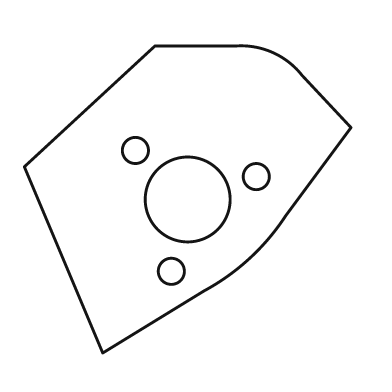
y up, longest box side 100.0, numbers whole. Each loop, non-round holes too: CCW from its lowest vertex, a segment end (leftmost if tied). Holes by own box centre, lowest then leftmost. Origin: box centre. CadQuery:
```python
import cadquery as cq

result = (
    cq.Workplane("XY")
    .moveTo(-26.0, -47.0)
    .lineTo(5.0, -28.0)
    .threePointArc((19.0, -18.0), (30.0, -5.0))
    .lineTo(50.0, 22.0)
    .lineTo(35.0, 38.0)
    .threePointArc((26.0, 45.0), (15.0, 47.0))
    .lineTo(-10.0, 47.0)
    .lineTo(-50.0, 10.0)
    .close()
    .moveTo(-5.0, -22.0)
    .circle(4.0)
    .moveTo(0.0, 0.0)
    .circle(13.0)
    .moveTo(21.0, 7.0)
    .circle(4.0)
    .moveTo(-16.0, 15.0)
    .circle(4.0)
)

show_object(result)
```